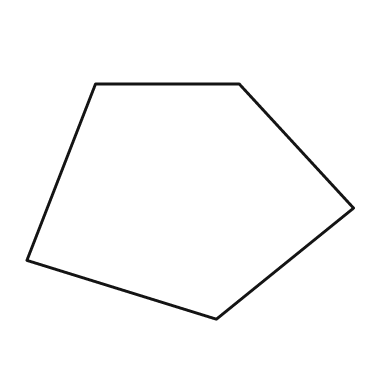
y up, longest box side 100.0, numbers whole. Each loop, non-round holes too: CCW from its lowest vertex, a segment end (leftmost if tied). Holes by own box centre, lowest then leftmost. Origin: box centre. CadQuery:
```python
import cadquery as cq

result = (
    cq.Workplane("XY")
    .moveTo(8.0, -36.0)
    .lineTo(50.0, -2.0)
    .lineTo(15.0, 36.0)
    .lineTo(-29.0, 36.0)
    .lineTo(-50.0, -18.0)
    .close()
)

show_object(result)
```